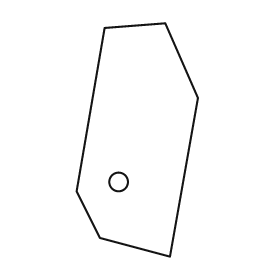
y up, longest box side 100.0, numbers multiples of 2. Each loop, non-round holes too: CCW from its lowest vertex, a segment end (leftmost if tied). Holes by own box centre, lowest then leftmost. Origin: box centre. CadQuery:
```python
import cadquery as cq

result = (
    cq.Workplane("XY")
    .moveTo(14.0, -50.0)
    .lineTo(26.0, 18.0)
    .lineTo(12.0, 50.0)
    .lineTo(-14.0, 48.0)
    .lineTo(-26.0, -22.0)
    .lineTo(-16.0, -42.0)
    .close()
    .moveTo(-8.0, -18.0)
    .circle(4.0)
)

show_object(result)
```